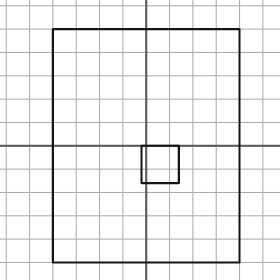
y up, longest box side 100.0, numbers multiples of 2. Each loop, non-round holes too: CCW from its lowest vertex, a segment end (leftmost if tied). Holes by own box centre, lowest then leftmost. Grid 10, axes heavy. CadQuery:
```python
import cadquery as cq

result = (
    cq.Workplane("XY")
    .moveTo(-40.0, -50.0)
    .lineTo(40.0, -50.0)
    .lineTo(40.0, 50.0)
    .lineTo(-40.0, 50.0)
    .close()
    .moveTo(-2.0, -16.0)
    .lineTo(14.0, -16.0)
    .lineTo(14.0, 0.0)
    .lineTo(-2.0, 0.0)
    .close()
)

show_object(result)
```